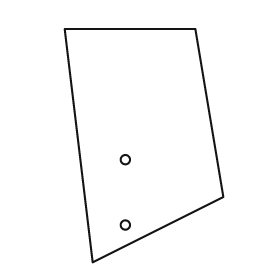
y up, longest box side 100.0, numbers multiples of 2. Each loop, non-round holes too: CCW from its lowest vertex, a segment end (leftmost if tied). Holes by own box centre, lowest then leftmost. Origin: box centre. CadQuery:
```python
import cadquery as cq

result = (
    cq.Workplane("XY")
    .moveTo(-22.0, -50.0)
    .lineTo(34.0, -22.0)
    .lineTo(22.0, 50.0)
    .lineTo(-34.0, 50.0)
    .close()
    .moveTo(-8.0, -34.0)
    .circle(2.0)
    .moveTo(-8.0, -6.0)
    .circle(2.0)
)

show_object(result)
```